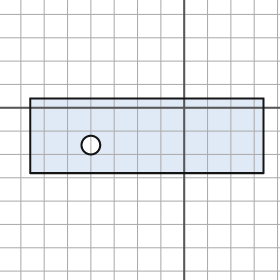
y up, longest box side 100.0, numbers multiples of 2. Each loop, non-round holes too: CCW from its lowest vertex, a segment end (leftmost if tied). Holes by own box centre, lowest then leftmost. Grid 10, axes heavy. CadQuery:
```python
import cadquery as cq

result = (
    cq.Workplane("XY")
    .moveTo(-66.0, -28.0)
    .lineTo(34.0, -28.0)
    .lineTo(34.0, 4.0)
    .lineTo(-66.0, 4.0)
    .close()
    .moveTo(-40.0, -16.0)
    .circle(4.0)
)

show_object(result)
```